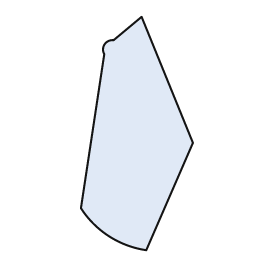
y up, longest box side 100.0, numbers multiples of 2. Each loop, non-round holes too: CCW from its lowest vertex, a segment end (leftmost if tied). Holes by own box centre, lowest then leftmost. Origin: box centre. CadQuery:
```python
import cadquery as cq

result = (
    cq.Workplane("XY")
    .moveTo(4.0, -50.0)
    .lineTo(24.0, -4.0)
    .lineTo(2.0, 50.0)
    .lineTo(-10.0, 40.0)
    .threePointArc((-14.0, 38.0), (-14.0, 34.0))
    .lineTo(-24.0, -32.0)
    .threePointArc((-12.0, -44.0), (4.0, -50.0))
    .close()
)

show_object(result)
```